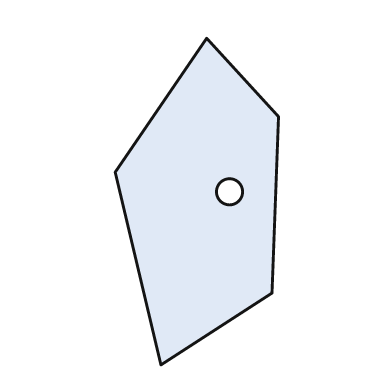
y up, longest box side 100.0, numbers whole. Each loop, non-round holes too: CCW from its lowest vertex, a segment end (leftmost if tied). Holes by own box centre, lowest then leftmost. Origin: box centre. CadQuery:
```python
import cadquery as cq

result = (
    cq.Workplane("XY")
    .moveTo(-11.0, -50.0)
    .lineTo(23.0, -28.0)
    .lineTo(25.0, 26.0)
    .lineTo(3.0, 50.0)
    .lineTo(-25.0, 9.0)
    .close()
    .moveTo(10.0, 3.0)
    .circle(4.0)
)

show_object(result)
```